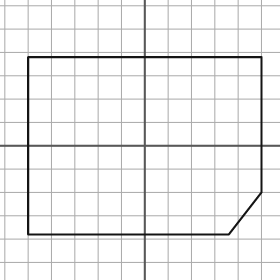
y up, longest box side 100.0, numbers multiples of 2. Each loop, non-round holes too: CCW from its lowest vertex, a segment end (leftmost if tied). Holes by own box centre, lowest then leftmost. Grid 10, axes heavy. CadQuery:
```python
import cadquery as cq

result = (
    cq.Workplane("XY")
    .moveTo(-50.0, -38.0)
    .lineTo(36.0, -38.0)
    .lineTo(50.0, -20.0)
    .lineTo(50.0, 38.0)
    .lineTo(-50.0, 38.0)
    .close()
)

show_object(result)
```